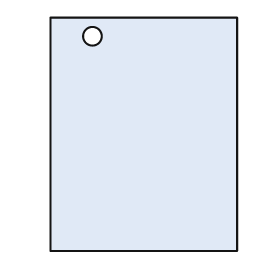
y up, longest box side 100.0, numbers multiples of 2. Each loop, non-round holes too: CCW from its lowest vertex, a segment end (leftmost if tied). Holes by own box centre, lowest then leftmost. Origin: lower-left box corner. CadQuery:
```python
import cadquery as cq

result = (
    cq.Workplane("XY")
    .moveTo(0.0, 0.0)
    .lineTo(80.0, 0.0)
    .lineTo(80.0, 100.0)
    .lineTo(0.0, 100.0)
    .close()
    .moveTo(18.0, 92.0)
    .circle(4.0)
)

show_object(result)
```